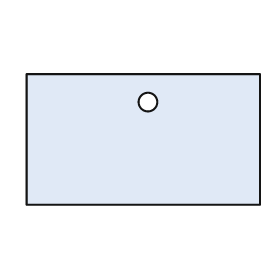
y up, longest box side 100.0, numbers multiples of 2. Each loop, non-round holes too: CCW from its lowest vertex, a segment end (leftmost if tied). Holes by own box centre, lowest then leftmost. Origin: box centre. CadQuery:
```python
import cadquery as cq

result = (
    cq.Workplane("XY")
    .moveTo(-50.0, -28.0)
    .lineTo(50.0, -28.0)
    .lineTo(50.0, 28.0)
    .lineTo(-50.0, 28.0)
    .close()
    .moveTo(2.0, 16.0)
    .circle(4.0)
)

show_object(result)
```